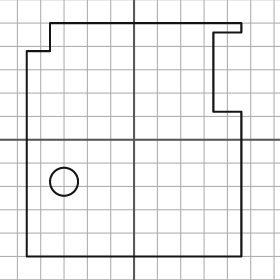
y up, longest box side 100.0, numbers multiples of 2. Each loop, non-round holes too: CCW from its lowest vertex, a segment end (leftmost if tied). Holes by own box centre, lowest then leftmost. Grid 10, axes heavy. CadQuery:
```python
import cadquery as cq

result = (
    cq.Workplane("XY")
    .moveTo(-46.0, -50.0)
    .lineTo(46.0, -50.0)
    .lineTo(46.0, 12.0)
    .lineTo(34.0, 12.0)
    .lineTo(34.0, 46.0)
    .lineTo(46.0, 46.0)
    .lineTo(46.0, 50.0)
    .lineTo(-36.0, 50.0)
    .lineTo(-36.0, 38.0)
    .lineTo(-46.0, 38.0)
    .close()
    .moveTo(-30.0, -18.0)
    .circle(6.0)
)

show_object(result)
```